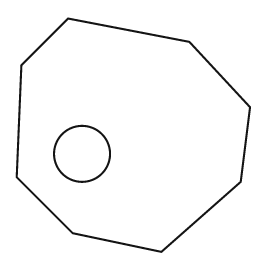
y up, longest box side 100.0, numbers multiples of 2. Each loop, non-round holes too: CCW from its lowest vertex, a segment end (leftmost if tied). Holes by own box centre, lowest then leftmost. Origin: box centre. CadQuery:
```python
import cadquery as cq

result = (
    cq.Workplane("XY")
    .moveTo(12.0, -50.0)
    .lineTo(46.0, -20.0)
    .lineTo(50.0, 12.0)
    .lineTo(24.0, 40.0)
    .lineTo(-28.0, 50.0)
    .lineTo(-48.0, 30.0)
    .lineTo(-50.0, -18.0)
    .lineTo(-26.0, -42.0)
    .close()
    .moveTo(-22.0, -8.0)
    .circle(12.0)
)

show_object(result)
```